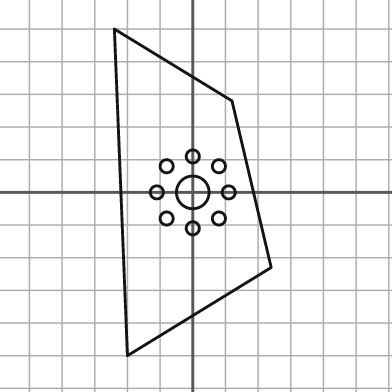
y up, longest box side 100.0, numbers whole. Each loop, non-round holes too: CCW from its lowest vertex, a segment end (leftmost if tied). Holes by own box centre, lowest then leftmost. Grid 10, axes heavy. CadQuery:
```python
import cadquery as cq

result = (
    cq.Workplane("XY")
    .moveTo(-20.0, -50.0)
    .lineTo(24.0, -23.0)
    .lineTo(12.0, 28.0)
    .lineTo(-24.0, 50.0)
    .close()
    .moveTo(0.0, -11.0)
    .circle(2.0)
    .moveTo(-8.0, -8.0)
    .circle(2.0)
    .moveTo(8.0, -8.0)
    .circle(2.0)
    .moveTo(-11.0, 0.0)
    .circle(2.0)
    .moveTo(0.0, 0.0)
    .circle(5.0)
    .moveTo(11.0, 0.0)
    .circle(2.0)
    .moveTo(-8.0, 8.0)
    .circle(2.0)
    .moveTo(8.0, 8.0)
    .circle(2.0)
    .moveTo(0.0, 11.0)
    .circle(2.0)
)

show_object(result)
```